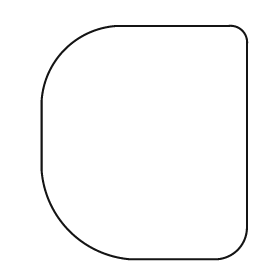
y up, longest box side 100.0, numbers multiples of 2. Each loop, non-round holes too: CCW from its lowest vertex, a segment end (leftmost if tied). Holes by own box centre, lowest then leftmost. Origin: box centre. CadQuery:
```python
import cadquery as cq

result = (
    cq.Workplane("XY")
    .moveTo(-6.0, -50.0)
    .lineTo(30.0, -50.0)
    .threePointArc((40.0, -46.0), (44.0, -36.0))
    .lineTo(44.0, 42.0)
    .threePointArc((42.0, 48.0), (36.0, 50.0))
    .lineTo(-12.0, 50.0)
    .threePointArc((-34.0, 40.0), (-44.0, 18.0))
    .lineTo(-44.0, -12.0)
    .threePointArc((-32.0, -38.0), (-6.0, -50.0))
    .close()
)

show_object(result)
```